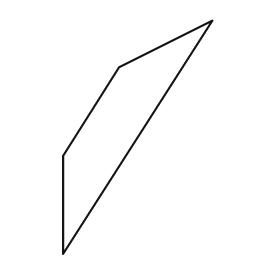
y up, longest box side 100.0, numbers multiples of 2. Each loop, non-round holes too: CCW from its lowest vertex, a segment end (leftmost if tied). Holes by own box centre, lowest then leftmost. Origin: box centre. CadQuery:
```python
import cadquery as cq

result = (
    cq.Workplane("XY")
    .moveTo(-32.0, -50.0)
    .lineTo(32.0, 50.0)
    .lineTo(-8.0, 30.0)
    .lineTo(-32.0, -8.0)
    .close()
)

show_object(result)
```